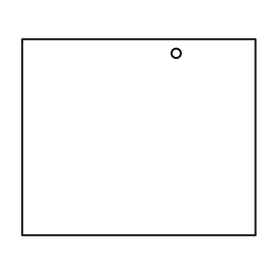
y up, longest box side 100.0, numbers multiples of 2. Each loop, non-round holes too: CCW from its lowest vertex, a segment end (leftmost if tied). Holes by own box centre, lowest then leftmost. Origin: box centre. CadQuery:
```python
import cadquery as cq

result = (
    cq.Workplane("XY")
    .moveTo(-50.0, -42.0)
    .lineTo(50.0, -42.0)
    .lineTo(50.0, 42.0)
    .lineTo(-50.0, 42.0)
    .close()
    .moveTo(16.0, 36.0)
    .circle(2.0)
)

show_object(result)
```